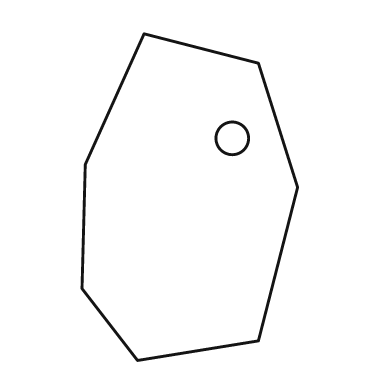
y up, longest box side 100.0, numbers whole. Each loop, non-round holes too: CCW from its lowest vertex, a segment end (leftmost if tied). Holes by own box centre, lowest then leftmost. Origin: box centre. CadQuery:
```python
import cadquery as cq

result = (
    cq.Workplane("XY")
    .moveTo(-16.0, -50.0)
    .lineTo(21.0, -44.0)
    .lineTo(33.0, 3.0)
    .lineTo(21.0, 41.0)
    .lineTo(-14.0, 50.0)
    .lineTo(-32.0, 10.0)
    .lineTo(-33.0, -28.0)
    .close()
    .moveTo(13.0, 18.0)
    .circle(5.0)
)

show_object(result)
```